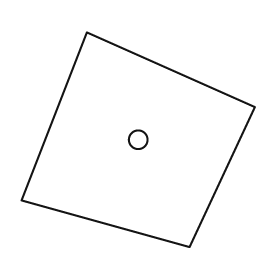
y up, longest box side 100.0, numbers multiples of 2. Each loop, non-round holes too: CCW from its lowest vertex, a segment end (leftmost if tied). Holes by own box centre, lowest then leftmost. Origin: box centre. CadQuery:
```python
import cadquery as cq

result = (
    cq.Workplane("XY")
    .moveTo(22.0, -46.0)
    .lineTo(50.0, 14.0)
    .lineTo(-22.0, 46.0)
    .lineTo(-50.0, -26.0)
    .close()
    .moveTo(0.0, 0.0)
    .circle(4.0)
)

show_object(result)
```